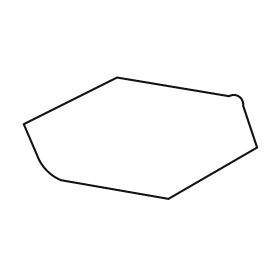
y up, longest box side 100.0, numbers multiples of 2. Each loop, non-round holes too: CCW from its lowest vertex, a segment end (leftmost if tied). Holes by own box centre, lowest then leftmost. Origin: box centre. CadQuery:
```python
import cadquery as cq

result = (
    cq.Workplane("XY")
    .moveTo(12.0, -26.0)
    .lineTo(50.0, -4.0)
    .lineTo(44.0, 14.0)
    .threePointArc((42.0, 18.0), (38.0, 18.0))
    .lineTo(-10.0, 26.0)
    .lineTo(-50.0, 6.0)
    .lineTo(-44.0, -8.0)
    .threePointArc((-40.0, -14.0), (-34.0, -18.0))
    .close()
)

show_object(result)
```